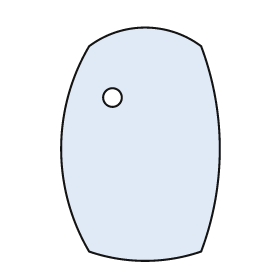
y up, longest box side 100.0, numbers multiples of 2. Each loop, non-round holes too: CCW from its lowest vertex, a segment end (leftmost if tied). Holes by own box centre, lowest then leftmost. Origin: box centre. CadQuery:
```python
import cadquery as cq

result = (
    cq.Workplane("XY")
    .moveTo(-22.0, -46.0)
    .threePointArc((2.0, -50.0), (26.0, -46.0))
    .threePointArc((34.0, -2.0), (26.0, 42.0))
    .threePointArc((2.0, 50.0), (-22.0, 42.0))
    .threePointArc((-34.0, -2.0), (-22.0, -46.0))
    .close()
    .moveTo(-12.0, 20.0)
    .circle(4.0)
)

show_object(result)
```